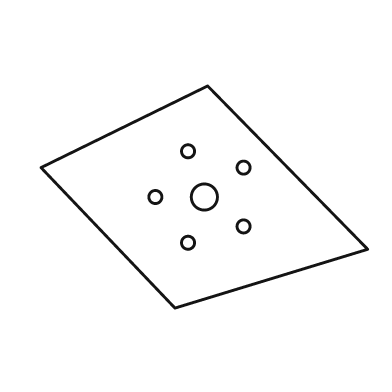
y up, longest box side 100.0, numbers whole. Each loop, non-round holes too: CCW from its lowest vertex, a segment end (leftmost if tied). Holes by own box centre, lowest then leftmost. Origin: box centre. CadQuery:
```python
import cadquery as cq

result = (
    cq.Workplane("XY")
    .moveTo(-9.0, -34.0)
    .lineTo(50.0, -16.0)
    .lineTo(1.0, 34.0)
    .lineTo(-50.0, 9.0)
    .close()
    .moveTo(-5.0, -14.0)
    .circle(2.0)
    .moveTo(12.0, -9.0)
    .circle(2.0)
    .moveTo(-15.0, 0.0)
    .circle(2.0)
    .moveTo(0.0, 0.0)
    .circle(4.0)
    .moveTo(12.0, 9.0)
    .circle(2.0)
    .moveTo(-5.0, 14.0)
    .circle(2.0)
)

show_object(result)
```